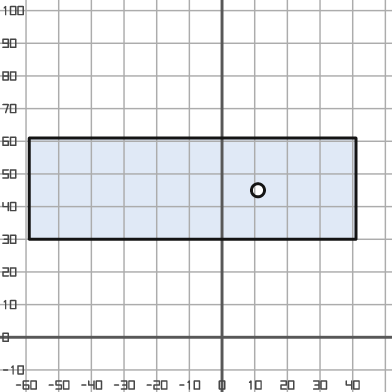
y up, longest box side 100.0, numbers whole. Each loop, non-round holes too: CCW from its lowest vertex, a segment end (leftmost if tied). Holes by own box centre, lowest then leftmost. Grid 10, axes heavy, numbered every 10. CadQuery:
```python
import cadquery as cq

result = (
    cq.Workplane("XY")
    .moveTo(-59.0, 30.0)
    .lineTo(41.0, 30.0)
    .lineTo(41.0, 61.0)
    .lineTo(-59.0, 61.0)
    .close()
    .moveTo(11.0, 45.0)
    .circle(2.0)
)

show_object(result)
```